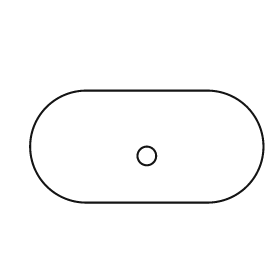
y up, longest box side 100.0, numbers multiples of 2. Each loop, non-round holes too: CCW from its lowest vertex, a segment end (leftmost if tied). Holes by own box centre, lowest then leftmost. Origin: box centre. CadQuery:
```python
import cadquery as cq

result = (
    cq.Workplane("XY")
    .moveTo(-26.0, -24.0)
    .lineTo(26.0, -24.0)
    .threePointArc((50.0, 0.0), (26.0, 24.0))
    .lineTo(-26.0, 24.0)
    .threePointArc((-50.0, 0.0), (-26.0, -24.0))
    .close()
    .moveTo(0.0, -4.0)
    .circle(4.0)
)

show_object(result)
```